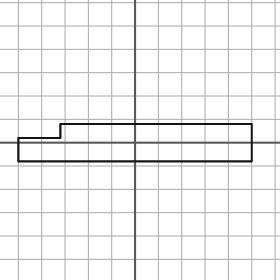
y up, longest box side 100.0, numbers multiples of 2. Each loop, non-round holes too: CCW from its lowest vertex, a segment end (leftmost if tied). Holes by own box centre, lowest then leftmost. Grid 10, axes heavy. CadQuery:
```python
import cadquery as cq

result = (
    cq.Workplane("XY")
    .moveTo(-50.0, -8.0)
    .lineTo(50.0, -8.0)
    .lineTo(50.0, 8.0)
    .lineTo(-32.0, 8.0)
    .lineTo(-32.0, 2.0)
    .lineTo(-50.0, 2.0)
    .close()
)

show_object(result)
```